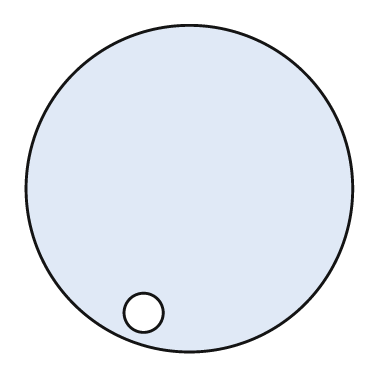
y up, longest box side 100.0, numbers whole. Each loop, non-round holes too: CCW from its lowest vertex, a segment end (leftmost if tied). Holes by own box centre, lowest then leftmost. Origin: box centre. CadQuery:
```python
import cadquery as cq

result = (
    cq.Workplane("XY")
    .moveTo(0.0, 0.0)
    .circle(50.0)
    .moveTo(-14.0, -38.0)
    .circle(6.0)
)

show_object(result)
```